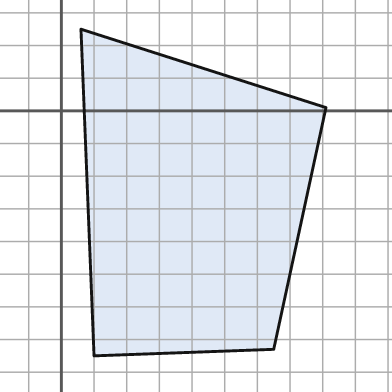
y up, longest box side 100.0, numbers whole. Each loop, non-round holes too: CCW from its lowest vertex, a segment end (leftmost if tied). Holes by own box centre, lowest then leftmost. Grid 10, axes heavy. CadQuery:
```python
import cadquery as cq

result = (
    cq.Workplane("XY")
    .moveTo(10.0, -75.0)
    .lineTo(65.0, -73.0)
    .lineTo(81.0, 1.0)
    .lineTo(6.0, 25.0)
    .close()
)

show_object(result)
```